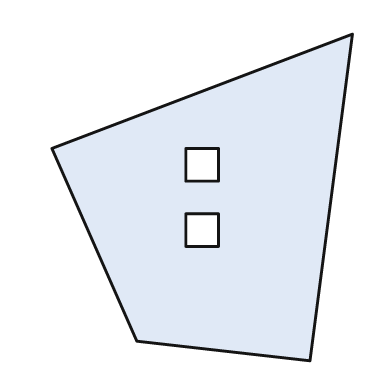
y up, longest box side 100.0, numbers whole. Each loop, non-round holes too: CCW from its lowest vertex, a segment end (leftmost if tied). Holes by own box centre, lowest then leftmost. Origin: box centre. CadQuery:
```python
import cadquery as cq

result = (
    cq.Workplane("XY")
    .moveTo(33.0, -50.0)
    .lineTo(46.0, 50.0)
    .lineTo(-46.0, 15.0)
    .lineTo(-20.0, -44.0)
    .close()
    .moveTo(-5.0, -15.0)
    .lineTo(5.0, -15.0)
    .lineTo(5.0, -5.0)
    .lineTo(-5.0, -5.0)
    .close()
    .moveTo(-5.0, 5.0)
    .lineTo(5.0, 5.0)
    .lineTo(5.0, 15.0)
    .lineTo(-5.0, 15.0)
    .close()
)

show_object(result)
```